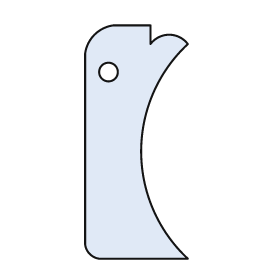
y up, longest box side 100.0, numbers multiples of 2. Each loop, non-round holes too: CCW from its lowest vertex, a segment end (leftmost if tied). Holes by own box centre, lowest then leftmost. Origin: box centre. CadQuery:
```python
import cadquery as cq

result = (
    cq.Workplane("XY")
    .moveTo(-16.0, -50.0)
    .lineTo(22.0, -50.0)
    .threePointArc((2.0, -4.0), (22.0, 42.0))
    .threePointArc((14.0, 46.0), (6.0, 42.0))
    .lineTo(6.0, 50.0)
    .lineTo(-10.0, 50.0)
    .threePointArc((-18.0, 46.0), (-22.0, 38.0))
    .lineTo(-22.0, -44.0)
    .threePointArc((-20.0, -48.0), (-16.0, -50.0))
    .close()
    .moveTo(-12.0, 30.0)
    .circle(4.0)
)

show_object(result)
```